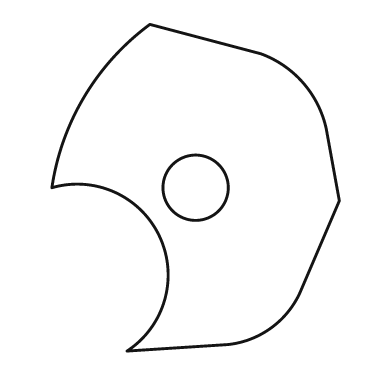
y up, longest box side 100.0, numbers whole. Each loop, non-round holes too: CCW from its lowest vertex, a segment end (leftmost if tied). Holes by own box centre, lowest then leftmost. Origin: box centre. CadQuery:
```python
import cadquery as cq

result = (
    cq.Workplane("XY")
    .moveTo(-21.0, -50.0)
    .lineTo(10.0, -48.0)
    .threePointArc((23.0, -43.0), (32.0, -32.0))
    .lineTo(44.0, -4.0)
    .lineTo(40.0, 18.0)
    .threePointArc((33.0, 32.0), (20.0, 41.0))
    .lineTo(-14.0, 50.0)
    .threePointArc((-34.0, 28.0), (-44.0, 0.0))
    .threePointArc((-11.0, -15.0), (-21.0, -50.0))
    .close()
    .moveTo(0.0, 0.0)
    .circle(10.0)
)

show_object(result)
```